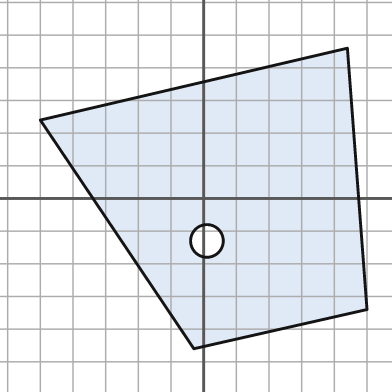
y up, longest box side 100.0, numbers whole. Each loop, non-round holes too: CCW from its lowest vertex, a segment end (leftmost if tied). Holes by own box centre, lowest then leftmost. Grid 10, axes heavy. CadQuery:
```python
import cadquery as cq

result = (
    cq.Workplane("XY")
    .moveTo(-3.0, -46.0)
    .lineTo(50.0, -34.0)
    .lineTo(44.0, 46.0)
    .lineTo(-50.0, 24.0)
    .close()
    .moveTo(1.0, -13.0)
    .circle(5.0)
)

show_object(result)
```